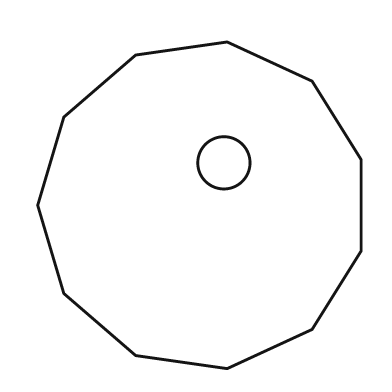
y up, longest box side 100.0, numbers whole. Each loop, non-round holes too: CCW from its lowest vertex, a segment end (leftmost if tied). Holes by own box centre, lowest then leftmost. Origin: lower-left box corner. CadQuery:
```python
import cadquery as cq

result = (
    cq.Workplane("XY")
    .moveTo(58.0, 0.0)
    .lineTo(84.0, 12.0)
    .lineTo(99.0, 36.0)
    .lineTo(99.0, 64.0)
    .lineTo(84.0, 88.0)
    .lineTo(58.0, 100.0)
    .lineTo(30.0, 96.0)
    .lineTo(8.0, 77.0)
    .lineTo(0.0, 50.0)
    .lineTo(8.0, 23.0)
    .lineTo(30.0, 4.0)
    .close()
    .moveTo(57.0, 63.0)
    .circle(8.0)
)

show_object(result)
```